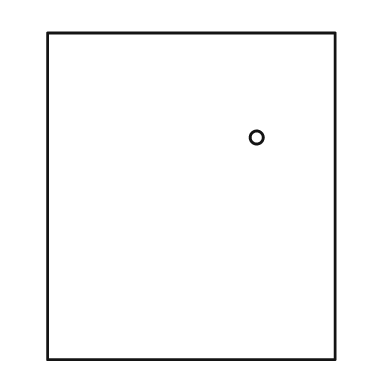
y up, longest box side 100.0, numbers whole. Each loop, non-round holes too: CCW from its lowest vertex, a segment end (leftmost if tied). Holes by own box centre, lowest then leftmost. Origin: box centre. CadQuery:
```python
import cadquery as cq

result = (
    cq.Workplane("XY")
    .moveTo(-44.0, -50.0)
    .lineTo(44.0, -50.0)
    .lineTo(44.0, 50.0)
    .lineTo(-44.0, 50.0)
    .close()
    .moveTo(20.0, 18.0)
    .circle(2.0)
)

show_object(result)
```